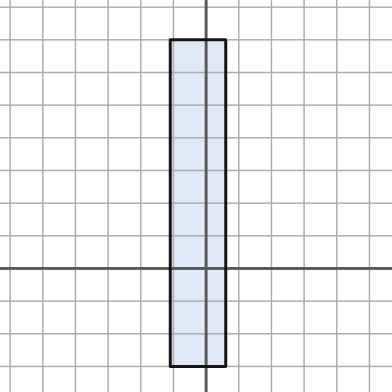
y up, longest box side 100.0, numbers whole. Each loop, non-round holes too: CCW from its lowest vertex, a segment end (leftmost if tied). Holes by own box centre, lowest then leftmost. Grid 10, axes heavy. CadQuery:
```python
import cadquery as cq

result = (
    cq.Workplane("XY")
    .moveTo(-11.0, -30.0)
    .lineTo(6.0, -30.0)
    .lineTo(6.0, 70.0)
    .lineTo(-11.0, 70.0)
    .close()
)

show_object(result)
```